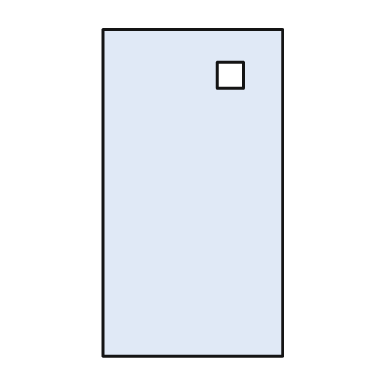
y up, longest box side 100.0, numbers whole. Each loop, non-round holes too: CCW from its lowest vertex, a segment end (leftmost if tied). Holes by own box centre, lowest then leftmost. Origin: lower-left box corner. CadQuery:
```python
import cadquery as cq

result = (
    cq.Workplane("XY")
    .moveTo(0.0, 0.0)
    .lineTo(55.0, 0.0)
    .lineTo(55.0, 100.0)
    .lineTo(0.0, 100.0)
    .close()
    .moveTo(35.0, 82.0)
    .lineTo(43.0, 82.0)
    .lineTo(43.0, 90.0)
    .lineTo(35.0, 90.0)
    .close()
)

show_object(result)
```